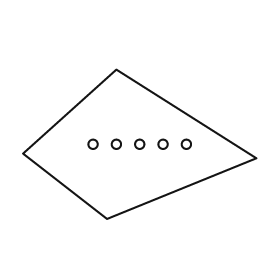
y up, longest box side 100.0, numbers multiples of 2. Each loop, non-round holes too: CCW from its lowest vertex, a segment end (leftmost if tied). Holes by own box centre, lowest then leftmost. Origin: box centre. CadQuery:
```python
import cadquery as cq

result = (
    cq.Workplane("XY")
    .moveTo(-14.0, -32.0)
    .lineTo(50.0, -6.0)
    .lineTo(-10.0, 32.0)
    .lineTo(-50.0, -4.0)
    .close()
    .moveTo(-20.0, 0.0)
    .circle(2.0)
    .moveTo(-10.0, 0.0)
    .circle(2.0)
    .moveTo(0.0, 0.0)
    .circle(2.0)
    .moveTo(10.0, 0.0)
    .circle(2.0)
    .moveTo(20.0, 0.0)
    .circle(2.0)
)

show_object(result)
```